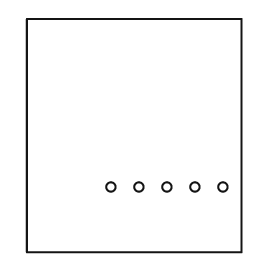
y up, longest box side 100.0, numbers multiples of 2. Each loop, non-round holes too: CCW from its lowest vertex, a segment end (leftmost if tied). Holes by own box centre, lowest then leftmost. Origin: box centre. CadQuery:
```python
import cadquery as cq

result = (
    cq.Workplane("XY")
    .moveTo(-46.0, -50.0)
    .lineTo(46.0, -50.0)
    .lineTo(46.0, 50.0)
    .lineTo(-46.0, 50.0)
    .close()
    .moveTo(-10.0, -22.0)
    .circle(2.0)
    .moveTo(2.0, -22.0)
    .circle(2.0)
    .moveTo(14.0, -22.0)
    .circle(2.0)
    .moveTo(26.0, -22.0)
    .circle(2.0)
    .moveTo(38.0, -22.0)
    .circle(2.0)
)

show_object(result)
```